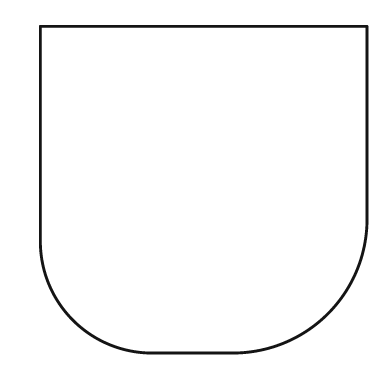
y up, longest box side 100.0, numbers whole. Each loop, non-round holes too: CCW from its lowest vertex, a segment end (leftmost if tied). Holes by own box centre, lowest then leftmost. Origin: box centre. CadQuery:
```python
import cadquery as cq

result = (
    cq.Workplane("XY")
    .moveTo(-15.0, -50.0)
    .lineTo(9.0, -50.0)
    .threePointArc((38.0, -38.0), (50.0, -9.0))
    .lineTo(50.0, 50.0)
    .lineTo(-50.0, 50.0)
    .lineTo(-50.0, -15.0)
    .threePointArc((-40.0, -40.0), (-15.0, -50.0))
    .close()
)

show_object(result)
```